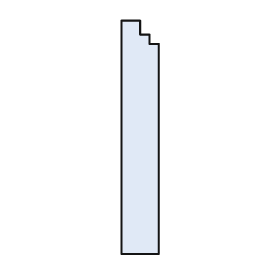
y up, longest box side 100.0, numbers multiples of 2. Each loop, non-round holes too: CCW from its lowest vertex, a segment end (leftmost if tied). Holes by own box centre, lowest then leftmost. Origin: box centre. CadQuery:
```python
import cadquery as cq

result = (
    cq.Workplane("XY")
    .moveTo(-8.0, -50.0)
    .lineTo(8.0, -50.0)
    .lineTo(8.0, 40.0)
    .lineTo(4.0, 40.0)
    .lineTo(4.0, 44.0)
    .lineTo(0.0, 44.0)
    .lineTo(0.0, 50.0)
    .lineTo(-8.0, 50.0)
    .close()
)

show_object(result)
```